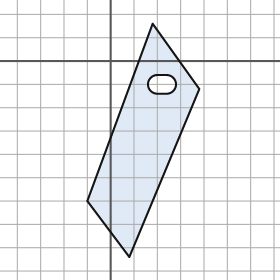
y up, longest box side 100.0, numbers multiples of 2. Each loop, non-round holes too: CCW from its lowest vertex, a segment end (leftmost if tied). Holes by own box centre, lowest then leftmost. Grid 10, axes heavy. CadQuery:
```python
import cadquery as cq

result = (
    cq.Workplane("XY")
    .moveTo(8.0, -84.0)
    .lineTo(38.0, -12.0)
    .lineTo(18.0, 16.0)
    .lineTo(-10.0, -60.0)
    .close()
    .moveTo(20.0, -14.0)
    .lineTo(24.0, -14.0)
    .threePointArc((28.0, -10.0), (24.0, -6.0))
    .lineTo(20.0, -6.0)
    .threePointArc((16.0, -10.0), (20.0, -14.0))
    .close()
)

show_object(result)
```